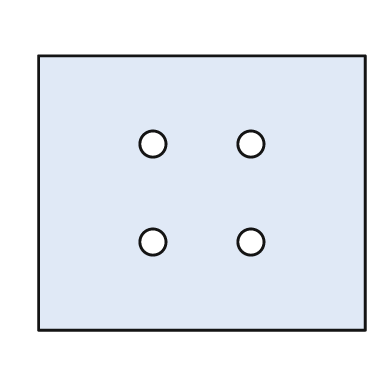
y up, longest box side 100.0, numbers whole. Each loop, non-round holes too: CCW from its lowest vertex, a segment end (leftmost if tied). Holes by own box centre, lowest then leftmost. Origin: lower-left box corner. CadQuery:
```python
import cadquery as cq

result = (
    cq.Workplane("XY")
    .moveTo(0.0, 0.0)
    .lineTo(100.0, 0.0)
    .lineTo(100.0, 84.0)
    .lineTo(0.0, 84.0)
    .close()
    .moveTo(35.0, 27.0)
    .circle(4.0)
    .moveTo(65.0, 27.0)
    .circle(4.0)
    .moveTo(35.0, 57.0)
    .circle(4.0)
    .moveTo(65.0, 57.0)
    .circle(4.0)
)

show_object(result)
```